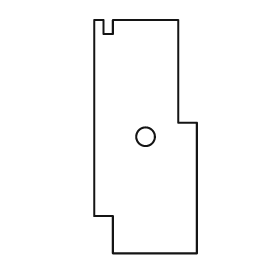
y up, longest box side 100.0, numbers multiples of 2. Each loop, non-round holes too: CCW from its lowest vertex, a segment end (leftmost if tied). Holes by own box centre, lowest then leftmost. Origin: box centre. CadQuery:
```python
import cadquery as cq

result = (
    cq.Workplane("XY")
    .moveTo(-14.0, -50.0)
    .lineTo(22.0, -50.0)
    .lineTo(22.0, 6.0)
    .lineTo(14.0, 6.0)
    .lineTo(14.0, 50.0)
    .lineTo(-14.0, 50.0)
    .lineTo(-14.0, 44.0)
    .lineTo(-18.0, 44.0)
    .lineTo(-18.0, 50.0)
    .lineTo(-22.0, 50.0)
    .lineTo(-22.0, -34.0)
    .lineTo(-14.0, -34.0)
    .close()
    .moveTo(0.0, 0.0)
    .circle(4.0)
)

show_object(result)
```